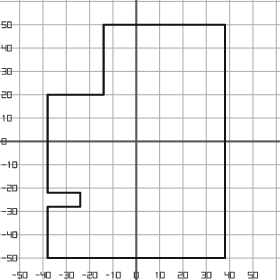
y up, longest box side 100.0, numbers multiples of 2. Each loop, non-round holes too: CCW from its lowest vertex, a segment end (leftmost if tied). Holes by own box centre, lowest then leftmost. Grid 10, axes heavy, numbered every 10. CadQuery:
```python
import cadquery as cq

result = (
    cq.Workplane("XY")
    .moveTo(-38.0, -50.0)
    .lineTo(38.0, -50.0)
    .lineTo(38.0, 50.0)
    .lineTo(-14.0, 50.0)
    .lineTo(-14.0, 20.0)
    .lineTo(-38.0, 20.0)
    .lineTo(-38.0, -22.0)
    .lineTo(-24.0, -22.0)
    .lineTo(-24.0, -28.0)
    .lineTo(-38.0, -28.0)
    .close()
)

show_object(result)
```